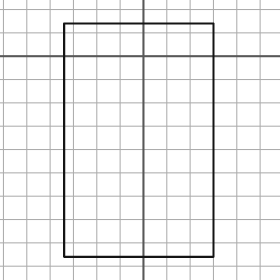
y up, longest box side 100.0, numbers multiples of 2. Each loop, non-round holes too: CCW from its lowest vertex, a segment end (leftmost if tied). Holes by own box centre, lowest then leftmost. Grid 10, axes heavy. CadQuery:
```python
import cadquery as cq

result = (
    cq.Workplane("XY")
    .moveTo(-34.0, -86.0)
    .lineTo(30.0, -86.0)
    .lineTo(30.0, 14.0)
    .lineTo(-34.0, 14.0)
    .close()
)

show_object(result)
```